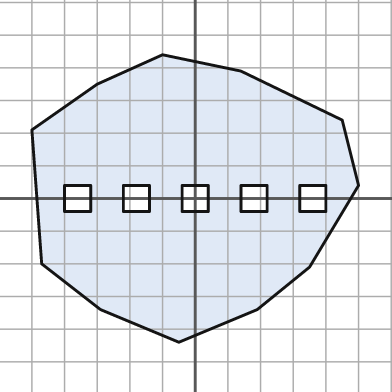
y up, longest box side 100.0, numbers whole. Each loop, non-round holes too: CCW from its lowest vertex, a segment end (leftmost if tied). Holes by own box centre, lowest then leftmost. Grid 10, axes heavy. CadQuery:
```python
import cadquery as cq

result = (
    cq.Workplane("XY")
    .moveTo(-5.0, -44.0)
    .lineTo(19.0, -34.0)
    .lineTo(35.0, -21.0)
    .lineTo(50.0, 4.0)
    .lineTo(45.0, 24.0)
    .lineTo(14.0, 39.0)
    .lineTo(-10.0, 44.0)
    .lineTo(-30.0, 35.0)
    .lineTo(-50.0, 21.0)
    .lineTo(-47.0, -20.0)
    .lineTo(-29.0, -34.0)
    .close()
    .moveTo(-40.0, -4.0)
    .lineTo(-32.0, -4.0)
    .lineTo(-32.0, 4.0)
    .lineTo(-40.0, 4.0)
    .close()
    .moveTo(-22.0, -4.0)
    .lineTo(-14.0, -4.0)
    .lineTo(-14.0, 4.0)
    .lineTo(-22.0, 4.0)
    .close()
    .moveTo(-4.0, -4.0)
    .lineTo(4.0, -4.0)
    .lineTo(4.0, 4.0)
    .lineTo(-4.0, 4.0)
    .close()
    .moveTo(14.0, -4.0)
    .lineTo(22.0, -4.0)
    .lineTo(22.0, 4.0)
    .lineTo(14.0, 4.0)
    .close()
    .moveTo(32.0, -4.0)
    .lineTo(40.0, -4.0)
    .lineTo(40.0, 4.0)
    .lineTo(32.0, 4.0)
    .close()
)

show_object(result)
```